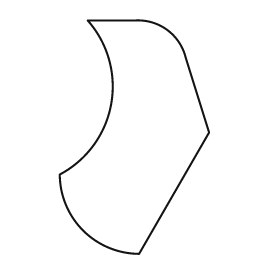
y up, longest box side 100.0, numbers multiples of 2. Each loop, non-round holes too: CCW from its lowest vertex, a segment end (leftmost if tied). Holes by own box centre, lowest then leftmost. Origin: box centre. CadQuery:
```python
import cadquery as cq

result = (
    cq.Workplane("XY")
    .moveTo(2.0, -50.0)
    .lineTo(32.0, 2.0)
    .lineTo(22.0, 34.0)
    .threePointArc((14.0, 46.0), (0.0, 50.0))
    .lineTo(-20.0, 50.0)
    .threePointArc((-10.0, 14.0), (-32.0, -16.0))
    .threePointArc((-22.0, -40.0), (2.0, -50.0))
    .close()
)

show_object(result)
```